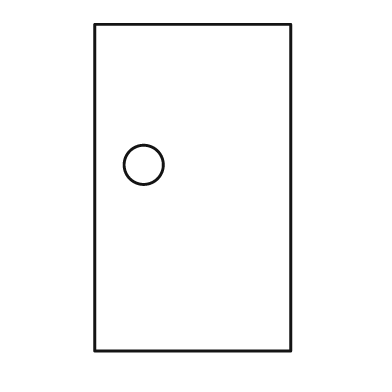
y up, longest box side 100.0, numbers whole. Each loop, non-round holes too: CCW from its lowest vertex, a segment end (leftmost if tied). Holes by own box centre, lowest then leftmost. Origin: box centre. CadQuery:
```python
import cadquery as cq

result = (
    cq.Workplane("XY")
    .moveTo(-30.0, -50.0)
    .lineTo(30.0, -50.0)
    .lineTo(30.0, 50.0)
    .lineTo(-30.0, 50.0)
    .close()
    .moveTo(-15.0, 7.0)
    .circle(6.0)
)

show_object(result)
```